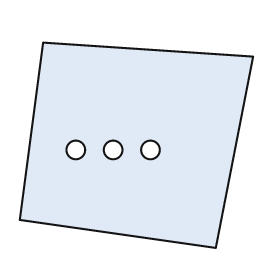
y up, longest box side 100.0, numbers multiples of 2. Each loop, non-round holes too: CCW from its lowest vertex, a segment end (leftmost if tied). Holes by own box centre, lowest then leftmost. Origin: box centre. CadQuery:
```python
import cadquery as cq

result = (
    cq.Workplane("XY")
    .moveTo(34.0, -44.0)
    .lineTo(50.0, 38.0)
    .lineTo(-40.0, 44.0)
    .lineTo(-50.0, -32.0)
    .close()
    .moveTo(-26.0, -2.0)
    .circle(4.0)
    .moveTo(-10.0, -2.0)
    .circle(4.0)
    .moveTo(6.0, -2.0)
    .circle(4.0)
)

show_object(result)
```